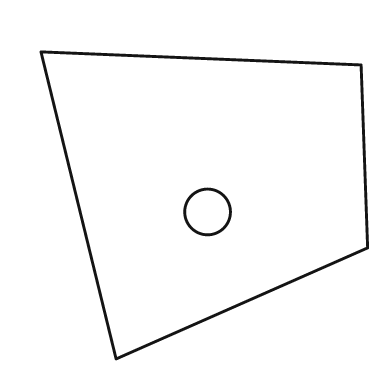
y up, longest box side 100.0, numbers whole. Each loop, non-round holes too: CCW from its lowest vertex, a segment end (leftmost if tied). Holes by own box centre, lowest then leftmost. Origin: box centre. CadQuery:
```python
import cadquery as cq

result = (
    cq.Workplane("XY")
    .moveTo(-27.0, -47.0)
    .lineTo(50.0, -13.0)
    .lineTo(48.0, 43.0)
    .lineTo(-50.0, 47.0)
    .close()
    .moveTo(1.0, -2.0)
    .circle(7.0)
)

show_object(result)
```